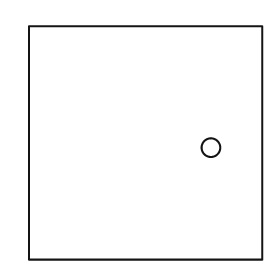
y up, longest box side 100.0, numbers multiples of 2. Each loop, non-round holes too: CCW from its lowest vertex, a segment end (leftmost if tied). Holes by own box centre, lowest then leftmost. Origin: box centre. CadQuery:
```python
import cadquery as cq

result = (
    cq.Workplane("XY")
    .moveTo(-50.0, -50.0)
    .lineTo(50.0, -50.0)
    .lineTo(50.0, 50.0)
    .lineTo(-50.0, 50.0)
    .close()
    .moveTo(28.0, -2.0)
    .circle(4.0)
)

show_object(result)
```